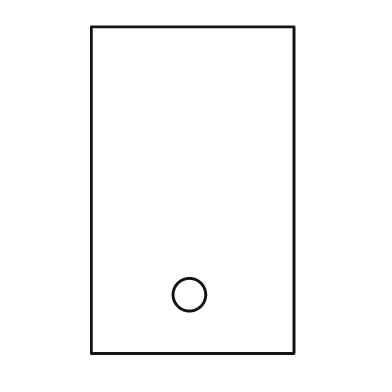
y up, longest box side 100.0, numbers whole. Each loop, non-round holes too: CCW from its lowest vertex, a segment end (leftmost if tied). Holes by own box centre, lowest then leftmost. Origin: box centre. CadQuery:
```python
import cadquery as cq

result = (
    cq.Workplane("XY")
    .moveTo(-31.0, -50.0)
    .lineTo(31.0, -50.0)
    .lineTo(31.0, 50.0)
    .lineTo(-31.0, 50.0)
    .close()
    .moveTo(-1.0, -32.0)
    .circle(5.0)
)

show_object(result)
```